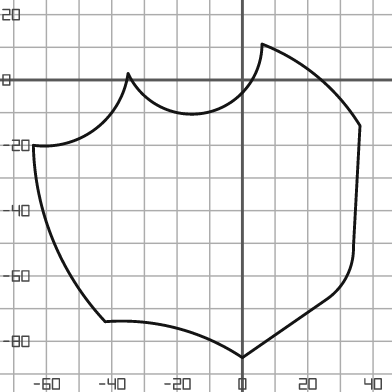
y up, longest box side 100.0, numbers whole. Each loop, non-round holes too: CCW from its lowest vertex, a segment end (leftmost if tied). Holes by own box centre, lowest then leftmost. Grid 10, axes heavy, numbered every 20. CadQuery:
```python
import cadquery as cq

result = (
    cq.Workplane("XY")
    .moveTo(0.0, -85.0)
    .lineTo(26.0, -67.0)
    .threePointArc((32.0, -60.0), (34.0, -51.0))
    .lineTo(36.0, -14.0)
    .threePointArc((23.0, 1.0), (6.0, 11.0))
    .threePointArc((-11.0, -10.0), (-35.0, 2.0))
    .threePointArc((-45.0, -15.0), (-64.0, -20.0))
    .threePointArc((-58.0, -49.0), (-42.0, -74.0))
    .threePointArc((-20.0, -76.0), (0.0, -85.0))
    .close()
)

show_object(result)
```